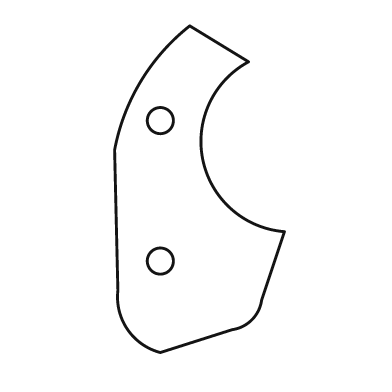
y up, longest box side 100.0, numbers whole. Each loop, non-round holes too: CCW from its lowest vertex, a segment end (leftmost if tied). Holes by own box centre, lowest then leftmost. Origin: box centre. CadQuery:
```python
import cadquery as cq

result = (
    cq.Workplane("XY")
    .moveTo(-12.0, -50.0)
    .lineTo(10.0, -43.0)
    .threePointArc((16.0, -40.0), (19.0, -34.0))
    .lineTo(26.0, -13.0)
    .threePointArc((1.0, 9.0), (15.0, 39.0))
    .lineTo(-3.0, 50.0)
    .threePointArc((-18.0, 33.0), (-26.0, 12.0))
    .lineTo(-25.0, -31.0)
    .threePointArc((-22.0, -43.0), (-12.0, -50.0))
    .close()
    .moveTo(-12.0, -22.0)
    .circle(4.0)
    .moveTo(-12.0, 21.0)
    .circle(4.0)
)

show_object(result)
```